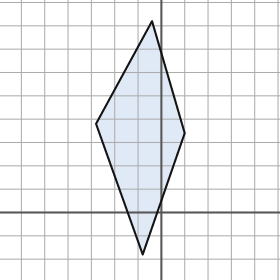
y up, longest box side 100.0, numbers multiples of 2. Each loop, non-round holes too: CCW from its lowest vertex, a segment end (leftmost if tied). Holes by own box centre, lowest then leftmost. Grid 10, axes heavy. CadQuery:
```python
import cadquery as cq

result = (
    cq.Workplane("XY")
    .moveTo(-8.0, -18.0)
    .lineTo(10.0, 34.0)
    .lineTo(-4.0, 82.0)
    .lineTo(-28.0, 38.0)
    .close()
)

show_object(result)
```